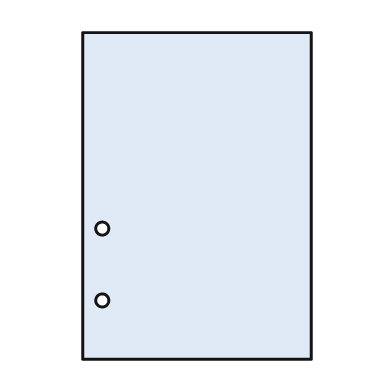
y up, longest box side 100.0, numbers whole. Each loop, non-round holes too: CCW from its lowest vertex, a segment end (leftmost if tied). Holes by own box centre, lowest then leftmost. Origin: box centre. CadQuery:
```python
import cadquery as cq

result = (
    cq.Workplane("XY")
    .moveTo(-35.0, -50.0)
    .lineTo(35.0, -50.0)
    .lineTo(35.0, 50.0)
    .lineTo(-35.0, 50.0)
    .close()
    .moveTo(-29.0, -32.0)
    .circle(2.0)
    .moveTo(-29.0, -10.0)
    .circle(2.0)
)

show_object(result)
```